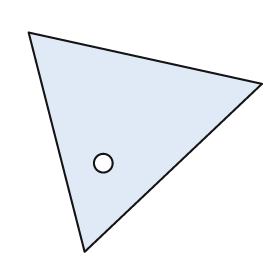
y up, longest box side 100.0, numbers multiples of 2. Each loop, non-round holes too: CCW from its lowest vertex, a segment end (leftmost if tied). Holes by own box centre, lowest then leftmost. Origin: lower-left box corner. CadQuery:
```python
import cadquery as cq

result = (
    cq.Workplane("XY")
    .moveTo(24.0, 0.0)
    .lineTo(100.0, 72.0)
    .lineTo(0.0, 94.0)
    .close()
    .moveTo(32.0, 38.0)
    .circle(4.0)
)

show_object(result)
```